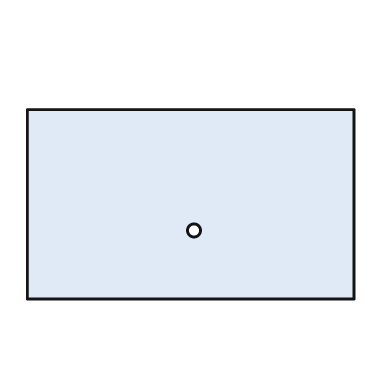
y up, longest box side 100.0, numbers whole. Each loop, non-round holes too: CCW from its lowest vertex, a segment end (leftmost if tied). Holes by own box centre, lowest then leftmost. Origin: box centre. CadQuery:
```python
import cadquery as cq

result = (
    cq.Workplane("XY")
    .moveTo(-50.0, -29.0)
    .lineTo(50.0, -29.0)
    .lineTo(50.0, 29.0)
    .lineTo(-50.0, 29.0)
    .close()
    .moveTo(1.0, -8.0)
    .circle(2.0)
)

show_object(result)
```